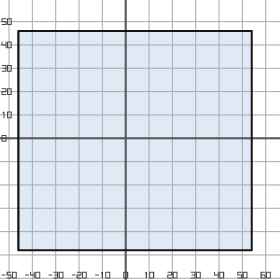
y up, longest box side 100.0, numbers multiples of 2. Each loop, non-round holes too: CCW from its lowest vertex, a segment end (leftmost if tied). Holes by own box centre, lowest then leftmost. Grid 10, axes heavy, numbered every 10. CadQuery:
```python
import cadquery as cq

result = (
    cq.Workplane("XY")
    .moveTo(-46.0, -48.0)
    .lineTo(54.0, -48.0)
    .lineTo(54.0, 46.0)
    .lineTo(-46.0, 46.0)
    .close()
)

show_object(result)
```